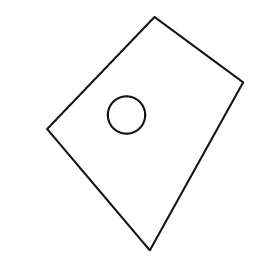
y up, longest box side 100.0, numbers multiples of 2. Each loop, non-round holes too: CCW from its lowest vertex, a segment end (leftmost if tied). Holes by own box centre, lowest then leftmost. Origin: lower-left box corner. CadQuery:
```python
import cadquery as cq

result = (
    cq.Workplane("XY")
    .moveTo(44.0, 0.0)
    .lineTo(84.0, 72.0)
    .lineTo(46.0, 100.0)
    .lineTo(0.0, 52.0)
    .close()
    .moveTo(34.0, 58.0)
    .circle(8.0)
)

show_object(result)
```